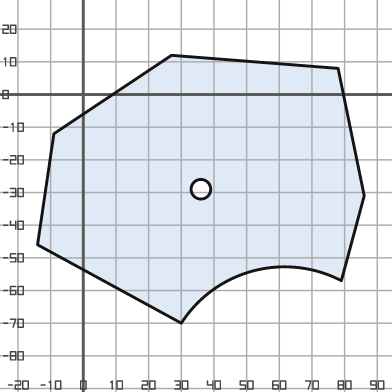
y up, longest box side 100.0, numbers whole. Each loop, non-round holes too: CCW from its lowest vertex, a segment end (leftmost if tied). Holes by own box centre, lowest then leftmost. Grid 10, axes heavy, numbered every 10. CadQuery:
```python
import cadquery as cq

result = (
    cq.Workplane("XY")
    .moveTo(30.0, -70.0)
    .threePointArc((52.0, -54.0), (79.0, -57.0))
    .lineTo(86.0, -31.0)
    .lineTo(78.0, 8.0)
    .lineTo(27.0, 12.0)
    .lineTo(-9.0, -12.0)
    .lineTo(-14.0, -46.0)
    .close()
    .moveTo(36.0, -29.0)
    .circle(3.0)
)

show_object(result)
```